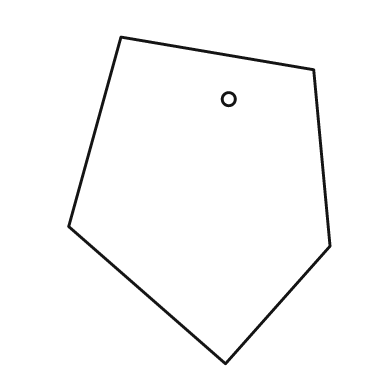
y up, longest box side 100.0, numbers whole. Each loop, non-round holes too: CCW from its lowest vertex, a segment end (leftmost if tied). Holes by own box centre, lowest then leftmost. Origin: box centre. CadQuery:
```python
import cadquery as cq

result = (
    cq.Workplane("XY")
    .moveTo(8.0, -50.0)
    .lineTo(40.0, -14.0)
    .lineTo(35.0, 40.0)
    .lineTo(-24.0, 50.0)
    .lineTo(-40.0, -8.0)
    .close()
    .moveTo(9.0, 31.0)
    .circle(2.0)
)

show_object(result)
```